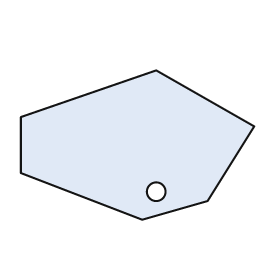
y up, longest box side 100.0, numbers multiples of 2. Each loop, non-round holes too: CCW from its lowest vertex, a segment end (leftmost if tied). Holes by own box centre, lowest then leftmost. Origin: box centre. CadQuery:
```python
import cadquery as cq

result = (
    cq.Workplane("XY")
    .moveTo(2.0, -32.0)
    .lineTo(30.0, -24.0)
    .lineTo(50.0, 8.0)
    .lineTo(8.0, 32.0)
    .lineTo(-50.0, 12.0)
    .lineTo(-50.0, -12.0)
    .close()
    .moveTo(8.0, -20.0)
    .circle(4.0)
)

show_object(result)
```